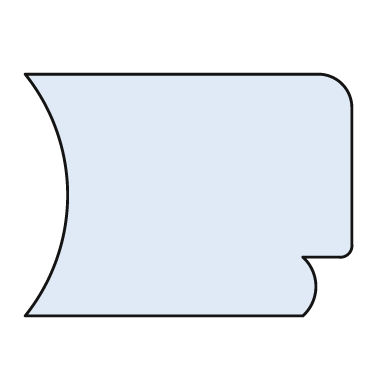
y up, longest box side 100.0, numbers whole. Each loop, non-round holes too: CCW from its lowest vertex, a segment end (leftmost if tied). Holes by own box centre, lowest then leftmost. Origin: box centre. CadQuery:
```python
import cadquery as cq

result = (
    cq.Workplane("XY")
    .moveTo(-50.0, -37.0)
    .lineTo(35.0, -37.0)
    .threePointArc((39.0, -28.0), (35.0, -19.0))
    .lineTo(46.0, -19.0)
    .threePointArc((49.0, -18.0), (50.0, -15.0))
    .lineTo(50.0, 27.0)
    .threePointArc((47.0, 34.0), (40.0, 37.0))
    .lineTo(-50.0, 37.0)
    .threePointArc((-37.0, 0.0), (-50.0, -37.0))
    .close()
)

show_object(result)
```